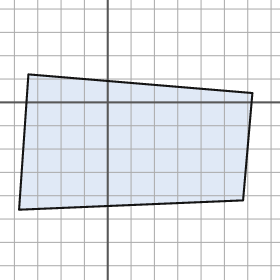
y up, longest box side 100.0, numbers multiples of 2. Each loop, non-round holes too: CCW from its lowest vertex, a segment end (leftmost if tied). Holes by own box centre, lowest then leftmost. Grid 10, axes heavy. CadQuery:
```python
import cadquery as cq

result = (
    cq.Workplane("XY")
    .moveTo(-38.0, -46.0)
    .lineTo(58.0, -42.0)
    .lineTo(62.0, 4.0)
    .lineTo(-34.0, 12.0)
    .close()
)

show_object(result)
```